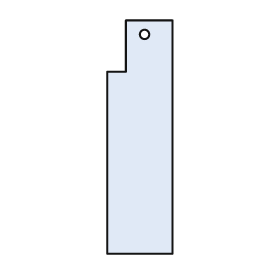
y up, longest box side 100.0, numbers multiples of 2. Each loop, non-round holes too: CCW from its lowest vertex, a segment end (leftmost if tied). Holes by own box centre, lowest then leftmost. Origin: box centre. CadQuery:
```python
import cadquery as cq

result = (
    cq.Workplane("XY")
    .moveTo(-14.0, -50.0)
    .lineTo(14.0, -50.0)
    .lineTo(14.0, 50.0)
    .lineTo(-6.0, 50.0)
    .lineTo(-6.0, 28.0)
    .lineTo(-14.0, 28.0)
    .close()
    .moveTo(2.0, 44.0)
    .circle(2.0)
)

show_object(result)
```